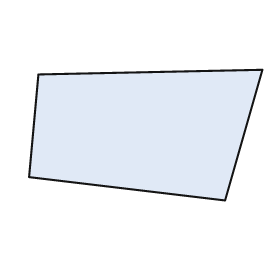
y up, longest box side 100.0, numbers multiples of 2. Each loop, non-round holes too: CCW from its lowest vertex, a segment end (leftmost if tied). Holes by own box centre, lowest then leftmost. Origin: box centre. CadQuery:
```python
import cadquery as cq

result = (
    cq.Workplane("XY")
    .moveTo(34.0, -28.0)
    .lineTo(50.0, 28.0)
    .lineTo(-46.0, 26.0)
    .lineTo(-50.0, -18.0)
    .close()
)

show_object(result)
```